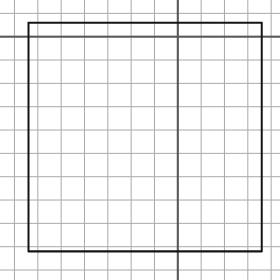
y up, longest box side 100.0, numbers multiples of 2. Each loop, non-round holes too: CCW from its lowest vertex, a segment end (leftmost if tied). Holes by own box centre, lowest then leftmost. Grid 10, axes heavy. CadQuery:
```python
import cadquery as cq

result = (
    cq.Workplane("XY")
    .moveTo(-64.0, -92.0)
    .lineTo(36.0, -92.0)
    .lineTo(36.0, 6.0)
    .lineTo(-64.0, 6.0)
    .close()
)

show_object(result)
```